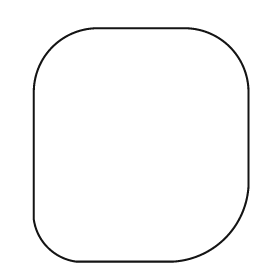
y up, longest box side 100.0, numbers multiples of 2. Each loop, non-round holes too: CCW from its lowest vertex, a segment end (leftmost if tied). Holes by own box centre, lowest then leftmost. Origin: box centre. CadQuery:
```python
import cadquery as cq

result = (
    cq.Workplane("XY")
    .moveTo(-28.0, -50.0)
    .lineTo(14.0, -50.0)
    .threePointArc((36.0, -40.0), (46.0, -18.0))
    .lineTo(46.0, 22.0)
    .threePointArc((38.0, 42.0), (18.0, 50.0))
    .lineTo(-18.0, 50.0)
    .threePointArc((-38.0, 42.0), (-46.0, 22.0))
    .lineTo(-46.0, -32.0)
    .threePointArc((-40.0, -44.0), (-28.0, -50.0))
    .close()
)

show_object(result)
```